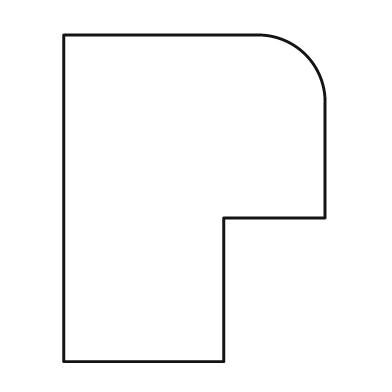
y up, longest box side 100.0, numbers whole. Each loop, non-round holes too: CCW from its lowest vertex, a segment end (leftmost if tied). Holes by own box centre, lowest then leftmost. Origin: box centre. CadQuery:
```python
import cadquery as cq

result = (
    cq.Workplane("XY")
    .moveTo(-40.0, -50.0)
    .lineTo(9.0, -50.0)
    .lineTo(9.0, -6.0)
    .lineTo(40.0, -6.0)
    .lineTo(40.0, 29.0)
    .threePointArc((34.0, 44.0), (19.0, 50.0))
    .lineTo(-40.0, 50.0)
    .close()
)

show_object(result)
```